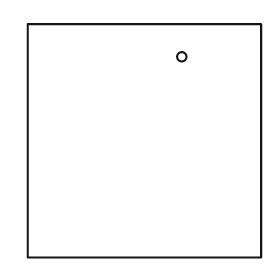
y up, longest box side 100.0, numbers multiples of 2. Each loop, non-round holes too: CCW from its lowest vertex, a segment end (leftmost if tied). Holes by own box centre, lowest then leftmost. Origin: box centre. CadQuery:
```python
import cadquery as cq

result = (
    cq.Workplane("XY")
    .moveTo(-50.0, -50.0)
    .lineTo(50.0, -50.0)
    .lineTo(50.0, 50.0)
    .lineTo(-50.0, 50.0)
    .close()
    .moveTo(16.0, 36.0)
    .circle(2.0)
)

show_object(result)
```